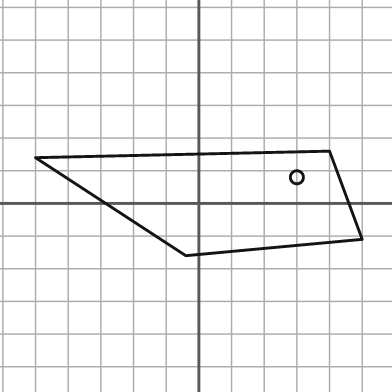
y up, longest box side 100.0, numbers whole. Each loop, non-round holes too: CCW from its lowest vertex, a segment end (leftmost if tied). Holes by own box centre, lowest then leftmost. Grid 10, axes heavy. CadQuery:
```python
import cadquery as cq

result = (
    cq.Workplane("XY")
    .moveTo(-4.0, -16.0)
    .lineTo(50.0, -11.0)
    .lineTo(40.0, 16.0)
    .lineTo(-50.0, 14.0)
    .close()
    .moveTo(30.0, 8.0)
    .circle(2.0)
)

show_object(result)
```